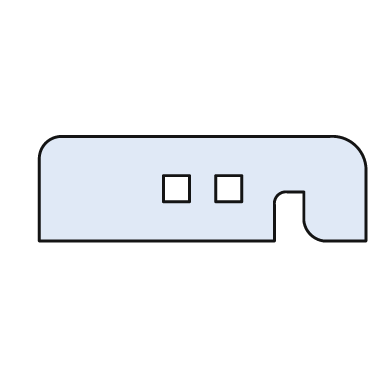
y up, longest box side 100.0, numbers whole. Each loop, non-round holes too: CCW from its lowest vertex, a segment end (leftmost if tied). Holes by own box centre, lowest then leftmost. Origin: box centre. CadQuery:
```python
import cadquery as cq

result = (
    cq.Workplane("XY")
    .moveTo(-50.0, -16.0)
    .lineTo(22.0, -16.0)
    .lineTo(22.0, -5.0)
    .threePointArc((23.0, -2.0), (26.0, -1.0))
    .lineTo(31.0, -1.0)
    .lineTo(31.0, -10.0)
    .threePointArc((33.0, -14.0), (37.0, -16.0))
    .lineTo(50.0, -16.0)
    .lineTo(50.0, 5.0)
    .threePointArc((47.0, 13.0), (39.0, 16.0))
    .lineTo(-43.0, 16.0)
    .threePointArc((-48.0, 14.0), (-50.0, 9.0))
    .close()
    .moveTo(-12.0, -4.0)
    .lineTo(-4.0, -4.0)
    .lineTo(-4.0, 4.0)
    .lineTo(-12.0, 4.0)
    .close()
    .moveTo(4.0, -4.0)
    .lineTo(12.0, -4.0)
    .lineTo(12.0, 4.0)
    .lineTo(4.0, 4.0)
    .close()
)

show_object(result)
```